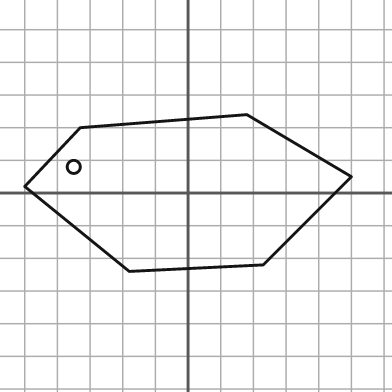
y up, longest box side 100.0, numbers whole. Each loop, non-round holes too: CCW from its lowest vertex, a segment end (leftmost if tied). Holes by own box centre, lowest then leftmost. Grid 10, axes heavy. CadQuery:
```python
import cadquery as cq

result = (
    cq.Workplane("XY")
    .moveTo(-18.0, -24.0)
    .lineTo(23.0, -22.0)
    .lineTo(50.0, 5.0)
    .lineTo(18.0, 24.0)
    .lineTo(-33.0, 20.0)
    .lineTo(-50.0, 2.0)
    .close()
    .moveTo(-35.0, 8.0)
    .circle(2.0)
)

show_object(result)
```